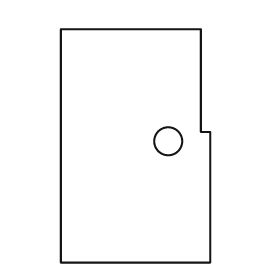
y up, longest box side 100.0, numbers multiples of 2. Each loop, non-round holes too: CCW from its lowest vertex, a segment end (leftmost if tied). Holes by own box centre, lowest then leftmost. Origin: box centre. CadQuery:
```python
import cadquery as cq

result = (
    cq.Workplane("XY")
    .moveTo(-32.0, -50.0)
    .lineTo(32.0, -50.0)
    .lineTo(32.0, 6.0)
    .lineTo(28.0, 6.0)
    .lineTo(28.0, 50.0)
    .lineTo(-32.0, 50.0)
    .close()
    .moveTo(14.0, 2.0)
    .circle(6.0)
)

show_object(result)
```